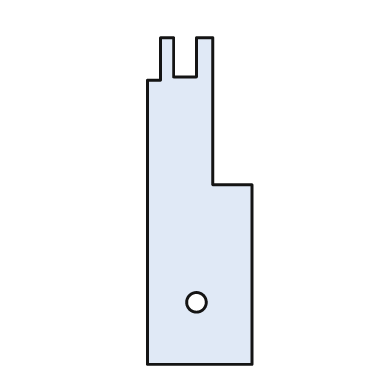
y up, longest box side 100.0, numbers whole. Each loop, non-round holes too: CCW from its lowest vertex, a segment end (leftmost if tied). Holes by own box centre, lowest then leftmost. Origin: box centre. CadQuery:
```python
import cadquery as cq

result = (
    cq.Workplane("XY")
    .moveTo(-16.0, -50.0)
    .lineTo(16.0, -50.0)
    .lineTo(16.0, 5.0)
    .lineTo(4.0, 5.0)
    .lineTo(4.0, 50.0)
    .lineTo(-1.0, 50.0)
    .lineTo(-1.0, 38.0)
    .lineTo(-8.0, 38.0)
    .lineTo(-8.0, 50.0)
    .lineTo(-12.0, 50.0)
    .lineTo(-12.0, 37.0)
    .lineTo(-16.0, 37.0)
    .close()
    .moveTo(-1.0, -31.0)
    .circle(3.0)
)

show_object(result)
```